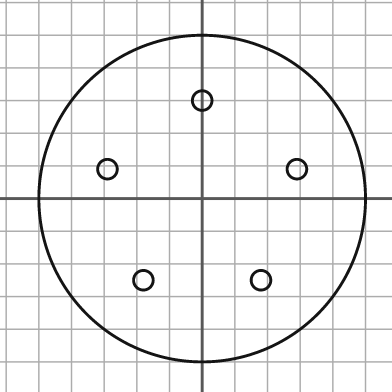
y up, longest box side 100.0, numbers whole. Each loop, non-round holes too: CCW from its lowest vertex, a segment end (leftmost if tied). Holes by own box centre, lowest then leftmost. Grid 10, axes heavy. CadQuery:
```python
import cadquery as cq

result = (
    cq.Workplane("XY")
    .moveTo(0.0, 0.0)
    .circle(50.0)
    .moveTo(-18.0, -25.0)
    .circle(3.0)
    .moveTo(18.0, -25.0)
    .circle(3.0)
    .moveTo(-29.0, 9.0)
    .circle(3.0)
    .moveTo(29.0, 9.0)
    .circle(3.0)
    .moveTo(0.0, 30.0)
    .circle(3.0)
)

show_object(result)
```